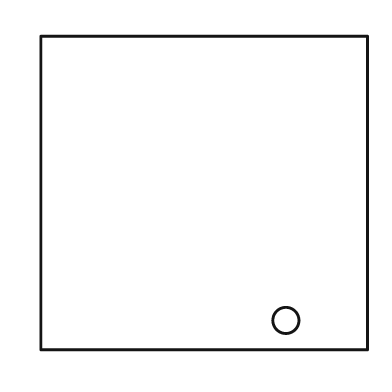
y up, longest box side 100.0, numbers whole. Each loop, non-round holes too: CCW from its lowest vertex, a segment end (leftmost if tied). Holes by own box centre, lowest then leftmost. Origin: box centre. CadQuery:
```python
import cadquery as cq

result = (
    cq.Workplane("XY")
    .moveTo(-50.0, -48.0)
    .lineTo(50.0, -48.0)
    .lineTo(50.0, 48.0)
    .lineTo(-50.0, 48.0)
    .close()
    .moveTo(25.0, -39.0)
    .circle(4.0)
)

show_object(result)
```